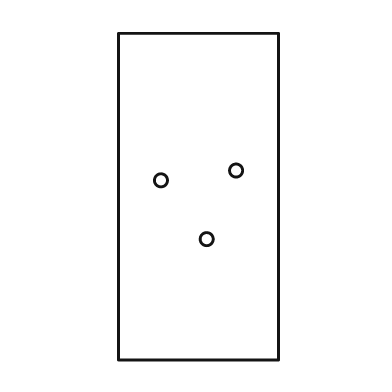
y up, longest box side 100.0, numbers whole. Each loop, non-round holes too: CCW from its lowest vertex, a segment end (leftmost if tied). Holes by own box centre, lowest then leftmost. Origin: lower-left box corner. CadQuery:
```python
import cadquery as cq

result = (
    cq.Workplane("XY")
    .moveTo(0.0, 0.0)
    .lineTo(49.0, 0.0)
    .lineTo(49.0, 100.0)
    .lineTo(0.0, 100.0)
    .close()
    .moveTo(27.0, 37.0)
    .circle(2.0)
    .moveTo(13.0, 55.0)
    .circle(2.0)
    .moveTo(36.0, 58.0)
    .circle(2.0)
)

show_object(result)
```